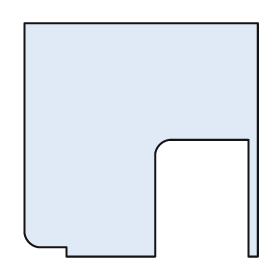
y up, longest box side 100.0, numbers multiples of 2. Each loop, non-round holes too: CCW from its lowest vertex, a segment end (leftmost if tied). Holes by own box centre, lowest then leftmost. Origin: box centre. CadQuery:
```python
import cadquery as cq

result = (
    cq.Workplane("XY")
    .moveTo(-32.0, -50.0)
    .lineTo(6.0, -50.0)
    .lineTo(6.0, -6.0)
    .threePointArc((8.0, -2.0), (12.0, 0.0))
    .lineTo(46.0, 0.0)
    .lineTo(46.0, -50.0)
    .lineTo(50.0, -50.0)
    .lineTo(50.0, 50.0)
    .lineTo(-50.0, 50.0)
    .lineTo(-50.0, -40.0)
    .threePointArc((-48.0, -44.0), (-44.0, -46.0))
    .lineTo(-32.0, -46.0)
    .close()
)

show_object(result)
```